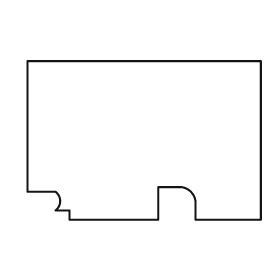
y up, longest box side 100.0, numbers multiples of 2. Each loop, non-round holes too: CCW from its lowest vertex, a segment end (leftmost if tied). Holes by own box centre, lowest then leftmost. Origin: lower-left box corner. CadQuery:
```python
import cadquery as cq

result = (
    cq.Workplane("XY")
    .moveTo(18.0, 0.0)
    .lineTo(56.0, 0.0)
    .lineTo(56.0, 14.0)
    .lineTo(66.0, 14.0)
    .threePointArc((70.0, 12.0), (72.0, 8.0))
    .lineTo(72.0, 0.0)
    .lineTo(100.0, 0.0)
    .lineTo(100.0, 68.0)
    .lineTo(0.0, 68.0)
    .lineTo(0.0, 12.0)
    .lineTo(12.0, 12.0)
    .threePointArc((14.0, 8.0), (12.0, 4.0))
    .lineTo(18.0, 4.0)
    .close()
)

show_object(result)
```